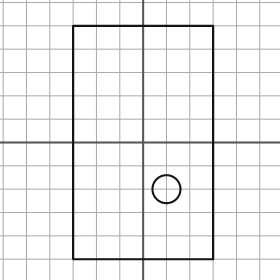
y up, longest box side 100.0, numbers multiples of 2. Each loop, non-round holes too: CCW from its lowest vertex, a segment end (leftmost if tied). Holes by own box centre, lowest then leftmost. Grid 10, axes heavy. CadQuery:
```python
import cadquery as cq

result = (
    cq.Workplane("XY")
    .moveTo(-30.0, -50.0)
    .lineTo(30.0, -50.0)
    .lineTo(30.0, 50.0)
    .lineTo(-30.0, 50.0)
    .close()
    .moveTo(10.0, -20.0)
    .circle(6.0)
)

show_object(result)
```